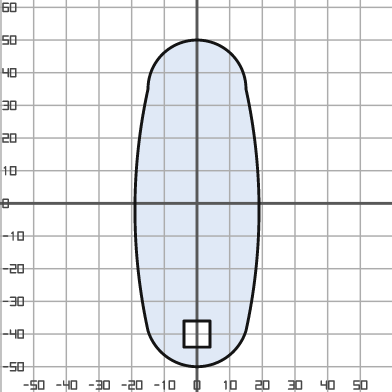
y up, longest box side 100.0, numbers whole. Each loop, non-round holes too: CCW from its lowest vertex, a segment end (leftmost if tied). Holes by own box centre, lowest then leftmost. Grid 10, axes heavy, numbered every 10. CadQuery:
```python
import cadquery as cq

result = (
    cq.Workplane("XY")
    .moveTo(-15.0, -39.0)
    .threePointArc((0.0, -50.0), (15.0, -39.0))
    .threePointArc((19.0, -2.0), (15.0, 35.0))
    .threePointArc((0.0, 50.0), (-15.0, 35.0))
    .threePointArc((-19.0, -2.0), (-15.0, -39.0))
    .close()
    .moveTo(-4.0, -44.0)
    .lineTo(4.0, -44.0)
    .lineTo(4.0, -36.0)
    .lineTo(-4.0, -36.0)
    .close()
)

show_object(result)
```